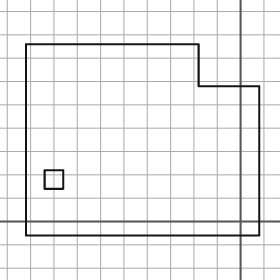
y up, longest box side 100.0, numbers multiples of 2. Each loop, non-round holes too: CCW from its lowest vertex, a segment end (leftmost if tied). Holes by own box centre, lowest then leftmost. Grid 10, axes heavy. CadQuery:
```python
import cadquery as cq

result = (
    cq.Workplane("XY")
    .moveTo(-92.0, -6.0)
    .lineTo(8.0, -6.0)
    .lineTo(8.0, 58.0)
    .lineTo(-18.0, 58.0)
    .lineTo(-18.0, 76.0)
    .lineTo(-92.0, 76.0)
    .close()
    .moveTo(-84.0, 14.0)
    .lineTo(-76.0, 14.0)
    .lineTo(-76.0, 22.0)
    .lineTo(-84.0, 22.0)
    .close()
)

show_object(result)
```